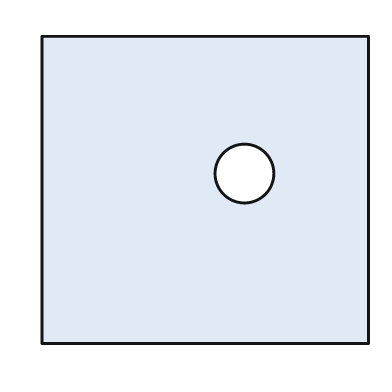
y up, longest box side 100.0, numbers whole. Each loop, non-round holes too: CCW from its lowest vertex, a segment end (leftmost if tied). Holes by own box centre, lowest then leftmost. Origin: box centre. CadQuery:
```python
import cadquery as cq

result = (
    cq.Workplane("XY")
    .moveTo(-50.0, -47.0)
    .lineTo(50.0, -47.0)
    .lineTo(50.0, 47.0)
    .lineTo(-50.0, 47.0)
    .close()
    .moveTo(12.0, 5.0)
    .circle(9.0)
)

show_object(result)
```